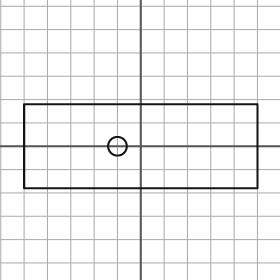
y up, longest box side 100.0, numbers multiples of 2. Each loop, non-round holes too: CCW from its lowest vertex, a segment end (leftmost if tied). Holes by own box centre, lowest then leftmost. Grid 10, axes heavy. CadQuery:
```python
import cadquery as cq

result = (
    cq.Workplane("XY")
    .moveTo(-50.0, -18.0)
    .lineTo(50.0, -18.0)
    .lineTo(50.0, 18.0)
    .lineTo(-50.0, 18.0)
    .close()
    .moveTo(-10.0, 0.0)
    .circle(4.0)
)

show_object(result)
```